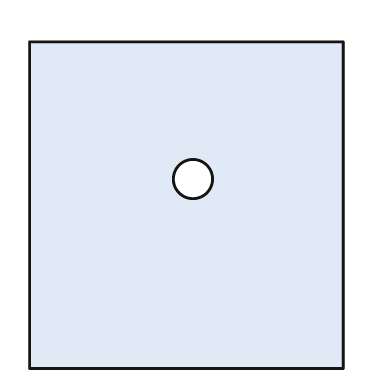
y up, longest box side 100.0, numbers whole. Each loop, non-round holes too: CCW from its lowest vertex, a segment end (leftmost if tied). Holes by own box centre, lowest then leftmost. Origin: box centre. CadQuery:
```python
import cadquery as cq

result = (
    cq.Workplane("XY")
    .moveTo(-48.0, -50.0)
    .lineTo(48.0, -50.0)
    .lineTo(48.0, 50.0)
    .lineTo(-48.0, 50.0)
    .close()
    .moveTo(2.0, 8.0)
    .circle(6.0)
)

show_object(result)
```